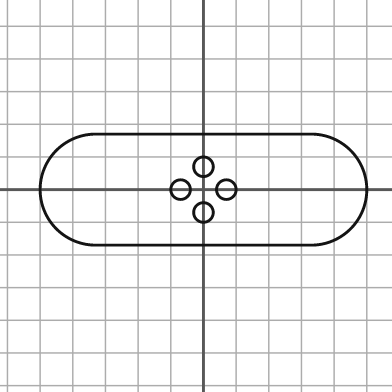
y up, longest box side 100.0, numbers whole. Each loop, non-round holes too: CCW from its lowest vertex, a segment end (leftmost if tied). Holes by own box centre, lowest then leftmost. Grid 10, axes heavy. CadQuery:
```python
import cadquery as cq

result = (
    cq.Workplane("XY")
    .moveTo(-33.0, -17.0)
    .lineTo(33.0, -17.0)
    .threePointArc((50.0, 0.0), (33.0, 17.0))
    .lineTo(-33.0, 17.0)
    .threePointArc((-50.0, 0.0), (-33.0, -17.0))
    .close()
    .moveTo(0.0, -7.0)
    .circle(3.0)
    .moveTo(-7.0, 0.0)
    .circle(3.0)
    .moveTo(7.0, 0.0)
    .circle(3.0)
    .moveTo(0.0, 7.0)
    .circle(3.0)
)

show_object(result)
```